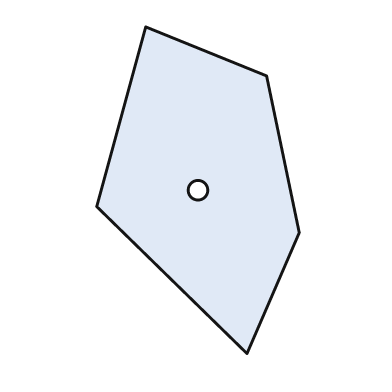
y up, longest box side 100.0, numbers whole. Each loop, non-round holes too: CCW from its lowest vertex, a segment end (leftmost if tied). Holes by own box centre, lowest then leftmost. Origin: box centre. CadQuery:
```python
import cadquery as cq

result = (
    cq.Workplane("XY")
    .moveTo(15.0, -50.0)
    .lineTo(31.0, -13.0)
    .lineTo(21.0, 35.0)
    .lineTo(-16.0, 50.0)
    .lineTo(-31.0, -5.0)
    .close()
    .moveTo(0.0, 0.0)
    .circle(3.0)
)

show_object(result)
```